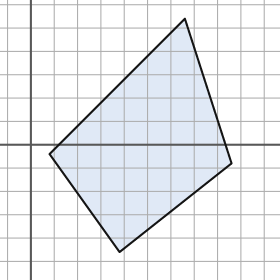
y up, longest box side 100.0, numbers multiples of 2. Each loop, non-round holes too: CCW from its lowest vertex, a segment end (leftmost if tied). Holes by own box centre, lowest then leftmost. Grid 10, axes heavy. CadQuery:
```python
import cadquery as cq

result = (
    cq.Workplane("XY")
    .moveTo(38.0, -46.0)
    .lineTo(86.0, -8.0)
    .lineTo(66.0, 54.0)
    .lineTo(8.0, -4.0)
    .close()
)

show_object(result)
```